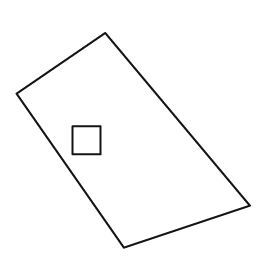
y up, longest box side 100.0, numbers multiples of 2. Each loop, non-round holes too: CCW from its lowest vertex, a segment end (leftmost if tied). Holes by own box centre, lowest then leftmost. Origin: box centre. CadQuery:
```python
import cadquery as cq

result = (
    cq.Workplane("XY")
    .moveTo(-4.0, -46.0)
    .lineTo(50.0, -28.0)
    .lineTo(-12.0, 46.0)
    .lineTo(-50.0, 20.0)
    .close()
    .moveTo(-26.0, -6.0)
    .lineTo(-14.0, -6.0)
    .lineTo(-14.0, 6.0)
    .lineTo(-26.0, 6.0)
    .close()
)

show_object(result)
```